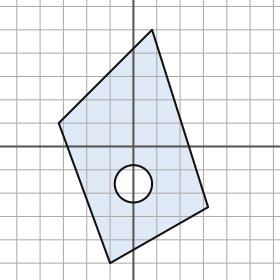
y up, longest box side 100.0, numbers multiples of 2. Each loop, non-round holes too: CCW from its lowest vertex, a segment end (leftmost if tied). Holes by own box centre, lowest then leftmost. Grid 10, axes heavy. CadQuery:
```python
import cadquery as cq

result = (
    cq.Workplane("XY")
    .moveTo(-10.0, -50.0)
    .lineTo(32.0, -26.0)
    .lineTo(8.0, 50.0)
    .lineTo(-32.0, 10.0)
    .close()
    .moveTo(0.0, -16.0)
    .circle(8.0)
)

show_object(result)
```